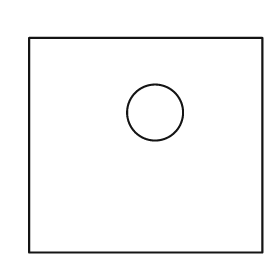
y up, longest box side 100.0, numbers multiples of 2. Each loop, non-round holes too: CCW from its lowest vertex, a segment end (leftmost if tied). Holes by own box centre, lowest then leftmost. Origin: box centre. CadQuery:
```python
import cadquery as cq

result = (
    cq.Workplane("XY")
    .moveTo(-50.0, -46.0)
    .lineTo(50.0, -46.0)
    .lineTo(50.0, 46.0)
    .lineTo(-50.0, 46.0)
    .close()
    .moveTo(4.0, 14.0)
    .circle(12.0)
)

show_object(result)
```